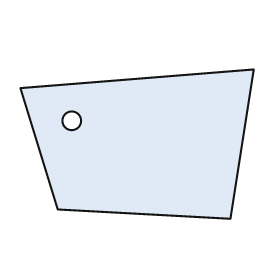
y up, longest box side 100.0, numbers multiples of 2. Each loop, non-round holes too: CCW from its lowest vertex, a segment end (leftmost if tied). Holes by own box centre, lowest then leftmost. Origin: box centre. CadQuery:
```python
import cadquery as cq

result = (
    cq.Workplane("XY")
    .moveTo(40.0, -32.0)
    .lineTo(50.0, 32.0)
    .lineTo(-50.0, 24.0)
    .lineTo(-34.0, -28.0)
    .close()
    .moveTo(-28.0, 10.0)
    .circle(4.0)
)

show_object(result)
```